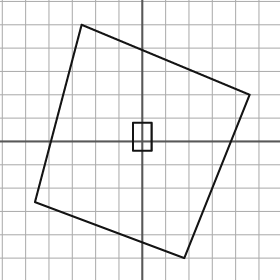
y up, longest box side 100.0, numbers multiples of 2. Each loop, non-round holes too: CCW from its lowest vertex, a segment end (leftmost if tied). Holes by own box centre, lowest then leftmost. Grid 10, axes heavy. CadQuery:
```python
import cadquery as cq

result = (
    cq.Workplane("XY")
    .moveTo(18.0, -50.0)
    .lineTo(46.0, 20.0)
    .lineTo(-26.0, 50.0)
    .lineTo(-46.0, -26.0)
    .close()
    .moveTo(-4.0, -4.0)
    .lineTo(4.0, -4.0)
    .lineTo(4.0, 8.0)
    .lineTo(-4.0, 8.0)
    .close()
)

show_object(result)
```